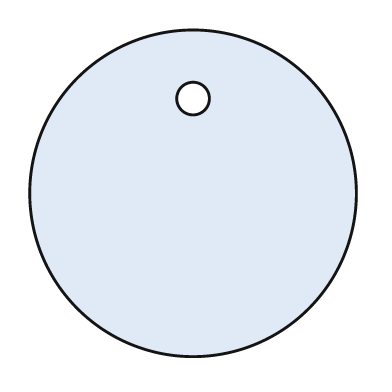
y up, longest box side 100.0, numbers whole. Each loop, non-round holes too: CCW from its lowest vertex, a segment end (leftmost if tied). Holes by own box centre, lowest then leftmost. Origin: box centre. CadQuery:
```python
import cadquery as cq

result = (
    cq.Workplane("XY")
    .moveTo(0.0, 0.0)
    .circle(50.0)
    .moveTo(0.0, 29.0)
    .circle(5.0)
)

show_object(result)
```